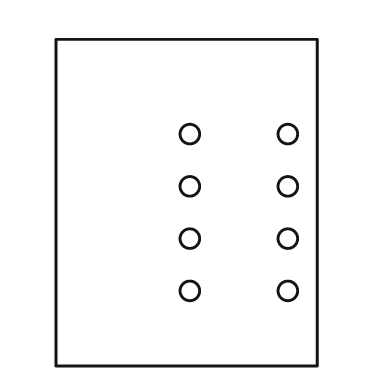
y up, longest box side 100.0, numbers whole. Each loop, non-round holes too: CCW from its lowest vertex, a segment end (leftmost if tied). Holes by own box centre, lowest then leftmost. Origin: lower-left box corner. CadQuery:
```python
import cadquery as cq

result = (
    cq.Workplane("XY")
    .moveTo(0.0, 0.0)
    .lineTo(80.0, 0.0)
    .lineTo(80.0, 100.0)
    .lineTo(0.0, 100.0)
    .close()
    .moveTo(41.0, 23.0)
    .circle(3.0)
    .moveTo(71.0, 23.0)
    .circle(3.0)
    .moveTo(41.0, 39.0)
    .circle(3.0)
    .moveTo(71.0, 39.0)
    .circle(3.0)
    .moveTo(41.0, 55.0)
    .circle(3.0)
    .moveTo(71.0, 55.0)
    .circle(3.0)
    .moveTo(41.0, 71.0)
    .circle(3.0)
    .moveTo(71.0, 71.0)
    .circle(3.0)
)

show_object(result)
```